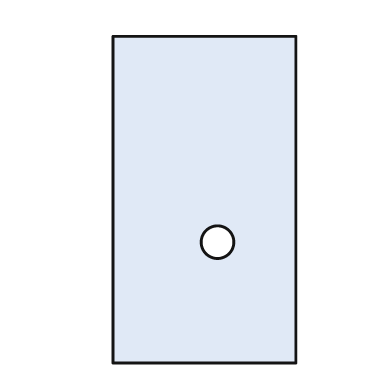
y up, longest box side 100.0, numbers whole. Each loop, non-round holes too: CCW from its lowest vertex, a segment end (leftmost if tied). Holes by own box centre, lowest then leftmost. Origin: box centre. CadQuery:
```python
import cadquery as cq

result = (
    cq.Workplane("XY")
    .moveTo(-28.0, -50.0)
    .lineTo(28.0, -50.0)
    .lineTo(28.0, 50.0)
    .lineTo(-28.0, 50.0)
    .close()
    .moveTo(4.0, -13.0)
    .circle(5.0)
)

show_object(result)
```